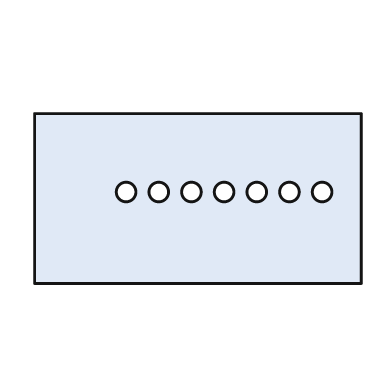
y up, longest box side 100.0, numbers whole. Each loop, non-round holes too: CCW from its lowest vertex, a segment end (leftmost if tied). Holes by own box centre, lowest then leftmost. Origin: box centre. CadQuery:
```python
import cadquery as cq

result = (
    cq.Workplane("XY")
    .moveTo(-50.0, -26.0)
    .lineTo(50.0, -26.0)
    .lineTo(50.0, 26.0)
    .lineTo(-50.0, 26.0)
    .close()
    .moveTo(-22.0, 2.0)
    .circle(3.0)
    .moveTo(-12.0, 2.0)
    .circle(3.0)
    .moveTo(-2.0, 2.0)
    .circle(3.0)
    .moveTo(8.0, 2.0)
    .circle(3.0)
    .moveTo(18.0, 2.0)
    .circle(3.0)
    .moveTo(28.0, 2.0)
    .circle(3.0)
    .moveTo(38.0, 2.0)
    .circle(3.0)
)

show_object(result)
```